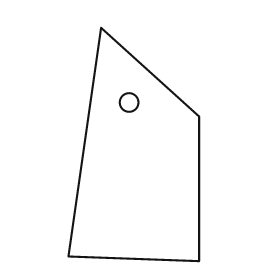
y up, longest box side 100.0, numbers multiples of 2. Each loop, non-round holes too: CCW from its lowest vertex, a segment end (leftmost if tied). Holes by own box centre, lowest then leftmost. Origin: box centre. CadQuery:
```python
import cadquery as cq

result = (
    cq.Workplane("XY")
    .moveTo(28.0, -50.0)
    .lineTo(28.0, 12.0)
    .lineTo(-14.0, 50.0)
    .lineTo(-28.0, -48.0)
    .close()
    .moveTo(-2.0, 18.0)
    .circle(4.0)
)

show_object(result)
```